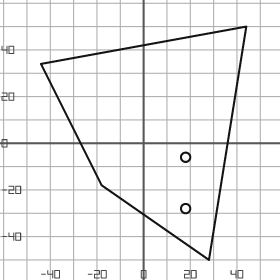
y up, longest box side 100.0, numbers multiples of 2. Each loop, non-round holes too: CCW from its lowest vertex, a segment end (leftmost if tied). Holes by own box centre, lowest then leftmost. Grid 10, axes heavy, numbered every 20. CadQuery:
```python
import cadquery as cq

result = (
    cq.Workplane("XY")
    .moveTo(28.0, -50.0)
    .lineTo(44.0, 50.0)
    .lineTo(-44.0, 34.0)
    .lineTo(-18.0, -18.0)
    .close()
    .moveTo(18.0, -28.0)
    .circle(2.0)
    .moveTo(18.0, -6.0)
    .circle(2.0)
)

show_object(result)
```